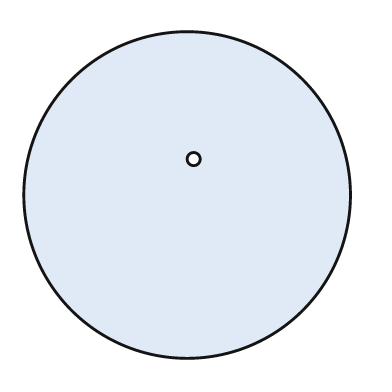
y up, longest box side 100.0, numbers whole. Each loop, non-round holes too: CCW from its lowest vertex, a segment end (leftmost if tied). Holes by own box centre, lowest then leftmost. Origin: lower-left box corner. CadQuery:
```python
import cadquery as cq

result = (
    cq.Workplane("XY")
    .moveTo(50.0, 50.0)
    .circle(50.0)
    .moveTo(52.0, 61.0)
    .circle(2.0)
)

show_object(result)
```